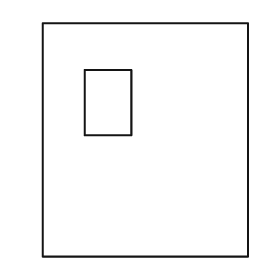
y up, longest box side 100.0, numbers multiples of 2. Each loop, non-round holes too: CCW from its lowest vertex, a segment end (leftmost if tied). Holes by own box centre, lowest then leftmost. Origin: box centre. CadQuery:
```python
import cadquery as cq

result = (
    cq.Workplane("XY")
    .moveTo(-44.0, -50.0)
    .lineTo(44.0, -50.0)
    .lineTo(44.0, 50.0)
    .lineTo(-44.0, 50.0)
    .close()
    .moveTo(-26.0, 2.0)
    .lineTo(-6.0, 2.0)
    .lineTo(-6.0, 30.0)
    .lineTo(-26.0, 30.0)
    .close()
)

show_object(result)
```